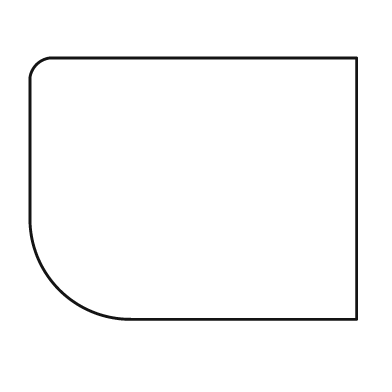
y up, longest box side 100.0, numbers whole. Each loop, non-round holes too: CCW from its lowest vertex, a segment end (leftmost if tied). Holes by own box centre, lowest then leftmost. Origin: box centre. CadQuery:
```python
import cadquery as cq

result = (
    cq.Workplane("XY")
    .moveTo(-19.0, -40.0)
    .lineTo(50.0, -40.0)
    .lineTo(50.0, 40.0)
    .lineTo(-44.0, 40.0)
    .threePointArc((-48.0, 38.0), (-50.0, 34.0))
    .lineTo(-50.0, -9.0)
    .threePointArc((-41.0, -31.0), (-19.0, -40.0))
    .close()
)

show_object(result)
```